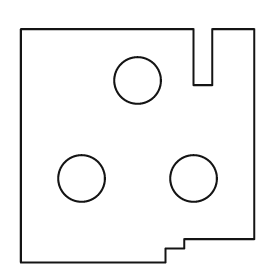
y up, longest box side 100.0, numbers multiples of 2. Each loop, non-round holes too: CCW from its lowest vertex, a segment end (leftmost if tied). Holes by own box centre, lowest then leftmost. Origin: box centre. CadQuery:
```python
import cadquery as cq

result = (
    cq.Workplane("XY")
    .moveTo(-50.0, -50.0)
    .lineTo(12.0, -50.0)
    .lineTo(12.0, -44.0)
    .lineTo(20.0, -44.0)
    .lineTo(20.0, -40.0)
    .lineTo(50.0, -40.0)
    .lineTo(50.0, 50.0)
    .lineTo(32.0, 50.0)
    .lineTo(32.0, 26.0)
    .lineTo(24.0, 26.0)
    .lineTo(24.0, 50.0)
    .lineTo(-50.0, 50.0)
    .close()
    .moveTo(-24.0, -14.0)
    .circle(10.0)
    .moveTo(24.0, -14.0)
    .circle(10.0)
    .moveTo(0.0, 28.0)
    .circle(10.0)
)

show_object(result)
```